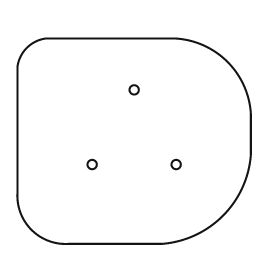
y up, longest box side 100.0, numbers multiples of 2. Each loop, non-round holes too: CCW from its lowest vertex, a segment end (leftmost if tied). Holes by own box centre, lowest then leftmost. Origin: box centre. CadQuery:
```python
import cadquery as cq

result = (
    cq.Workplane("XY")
    .moveTo(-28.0, -44.0)
    .lineTo(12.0, -44.0)
    .threePointArc((38.0, -32.0), (50.0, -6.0))
    .lineTo(50.0, 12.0)
    .threePointArc((40.0, 34.0), (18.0, 44.0))
    .lineTo(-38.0, 44.0)
    .threePointArc((-46.0, 40.0), (-50.0, 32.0))
    .lineTo(-50.0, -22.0)
    .threePointArc((-44.0, -38.0), (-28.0, -44.0))
    .close()
    .moveTo(-18.0, -10.0)
    .circle(2.0)
    .moveTo(18.0, -10.0)
    .circle(2.0)
    .moveTo(0.0, 22.0)
    .circle(2.0)
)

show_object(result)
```